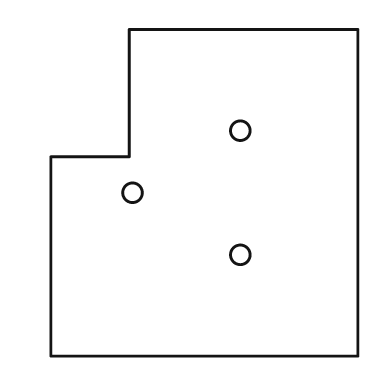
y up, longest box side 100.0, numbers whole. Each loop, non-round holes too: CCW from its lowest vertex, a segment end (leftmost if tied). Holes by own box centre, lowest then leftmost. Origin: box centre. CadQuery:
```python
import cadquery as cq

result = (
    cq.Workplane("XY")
    .moveTo(-47.0, -50.0)
    .lineTo(47.0, -50.0)
    .lineTo(47.0, 50.0)
    .lineTo(-23.0, 50.0)
    .lineTo(-23.0, 11.0)
    .lineTo(-47.0, 11.0)
    .close()
    .moveTo(11.0, -19.0)
    .circle(3.0)
    .moveTo(-22.0, 0.0)
    .circle(3.0)
    .moveTo(11.0, 19.0)
    .circle(3.0)
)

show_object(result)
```